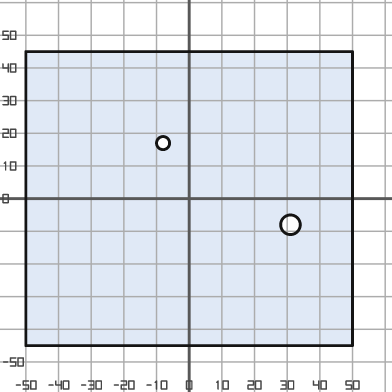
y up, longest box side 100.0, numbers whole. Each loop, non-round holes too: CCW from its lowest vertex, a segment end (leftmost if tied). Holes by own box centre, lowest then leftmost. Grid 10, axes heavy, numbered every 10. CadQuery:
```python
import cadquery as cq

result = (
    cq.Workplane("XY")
    .moveTo(-50.0, -45.0)
    .lineTo(50.0, -45.0)
    .lineTo(50.0, 45.0)
    .lineTo(-50.0, 45.0)
    .close()
    .moveTo(31.0, -8.0)
    .circle(3.0)
    .moveTo(-8.0, 17.0)
    .circle(2.0)
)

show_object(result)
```